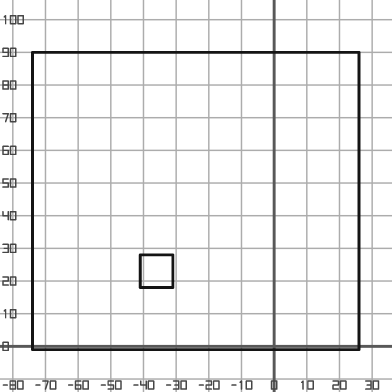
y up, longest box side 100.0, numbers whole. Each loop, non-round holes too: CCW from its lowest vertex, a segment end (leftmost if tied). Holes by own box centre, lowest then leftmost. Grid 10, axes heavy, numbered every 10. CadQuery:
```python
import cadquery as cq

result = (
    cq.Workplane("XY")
    .moveTo(-74.0, -1.0)
    .lineTo(26.0, -1.0)
    .lineTo(26.0, 90.0)
    .lineTo(-74.0, 90.0)
    .close()
    .moveTo(-41.0, 18.0)
    .lineTo(-31.0, 18.0)
    .lineTo(-31.0, 28.0)
    .lineTo(-41.0, 28.0)
    .close()
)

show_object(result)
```